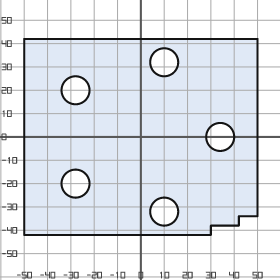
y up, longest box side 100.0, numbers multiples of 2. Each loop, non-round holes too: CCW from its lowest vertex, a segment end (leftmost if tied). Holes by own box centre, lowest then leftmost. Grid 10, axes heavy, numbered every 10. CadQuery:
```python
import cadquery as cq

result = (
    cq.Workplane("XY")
    .moveTo(-50.0, -42.0)
    .lineTo(30.0, -42.0)
    .lineTo(30.0, -38.0)
    .lineTo(42.0, -38.0)
    .lineTo(42.0, -34.0)
    .lineTo(50.0, -34.0)
    .lineTo(50.0, 42.0)
    .lineTo(-50.0, 42.0)
    .close()
    .moveTo(10.0, -32.0)
    .circle(6.0)
    .moveTo(-28.0, -20.0)
    .circle(6.0)
    .moveTo(34.0, 0.0)
    .circle(6.0)
    .moveTo(-28.0, 20.0)
    .circle(6.0)
    .moveTo(10.0, 32.0)
    .circle(6.0)
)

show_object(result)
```